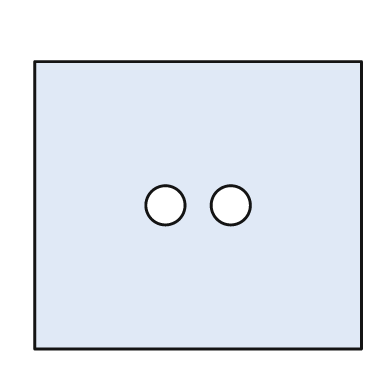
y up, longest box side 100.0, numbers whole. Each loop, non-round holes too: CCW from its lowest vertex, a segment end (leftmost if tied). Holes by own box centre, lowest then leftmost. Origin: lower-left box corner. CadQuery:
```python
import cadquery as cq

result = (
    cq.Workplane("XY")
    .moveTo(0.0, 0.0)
    .lineTo(100.0, 0.0)
    .lineTo(100.0, 88.0)
    .lineTo(0.0, 88.0)
    .close()
    .moveTo(40.0, 44.0)
    .circle(6.0)
    .moveTo(60.0, 44.0)
    .circle(6.0)
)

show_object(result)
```